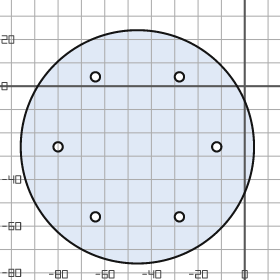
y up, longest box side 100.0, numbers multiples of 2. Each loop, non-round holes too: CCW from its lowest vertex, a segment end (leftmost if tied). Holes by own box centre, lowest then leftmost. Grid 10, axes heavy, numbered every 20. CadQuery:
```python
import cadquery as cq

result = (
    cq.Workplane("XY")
    .moveTo(-46.0, -26.0)
    .circle(50.0)
    .moveTo(-64.0, -56.0)
    .circle(2.0)
    .moveTo(-28.0, -56.0)
    .circle(2.0)
    .moveTo(-80.0, -26.0)
    .circle(2.0)
    .moveTo(-12.0, -26.0)
    .circle(2.0)
    .moveTo(-64.0, 4.0)
    .circle(2.0)
    .moveTo(-28.0, 4.0)
    .circle(2.0)
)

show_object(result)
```